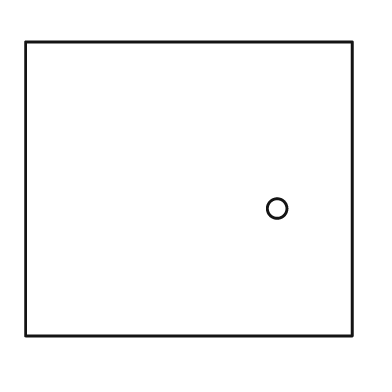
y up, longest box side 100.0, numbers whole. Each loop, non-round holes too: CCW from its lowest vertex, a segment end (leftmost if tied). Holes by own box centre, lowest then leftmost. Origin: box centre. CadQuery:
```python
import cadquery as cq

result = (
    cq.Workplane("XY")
    .moveTo(-50.0, -45.0)
    .lineTo(50.0, -45.0)
    .lineTo(50.0, 45.0)
    .lineTo(-50.0, 45.0)
    .close()
    .moveTo(27.0, -6.0)
    .circle(3.0)
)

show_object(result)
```